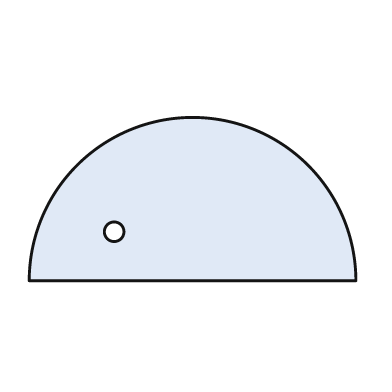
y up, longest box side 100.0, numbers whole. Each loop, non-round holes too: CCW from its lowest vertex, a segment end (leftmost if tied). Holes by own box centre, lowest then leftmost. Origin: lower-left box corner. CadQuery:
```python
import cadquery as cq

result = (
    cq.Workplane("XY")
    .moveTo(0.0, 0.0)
    .lineTo(100.0, 0.0)
    .threePointArc((50.0, 50.0), (0.0, 0.0))
    .close()
    .moveTo(26.0, 15.0)
    .circle(3.0)
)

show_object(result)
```